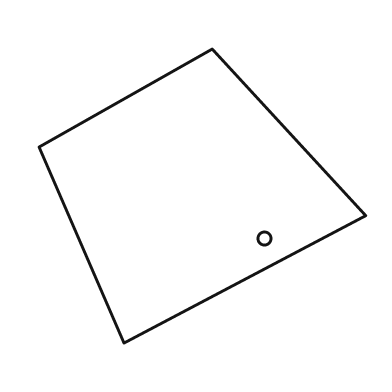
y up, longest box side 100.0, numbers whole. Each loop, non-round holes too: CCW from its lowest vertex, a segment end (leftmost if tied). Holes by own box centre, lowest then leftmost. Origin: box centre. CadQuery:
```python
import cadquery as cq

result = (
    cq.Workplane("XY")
    .moveTo(-24.0, -45.0)
    .lineTo(50.0, -6.0)
    .lineTo(3.0, 45.0)
    .lineTo(-50.0, 15.0)
    .close()
    .moveTo(19.0, -13.0)
    .circle(2.0)
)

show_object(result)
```